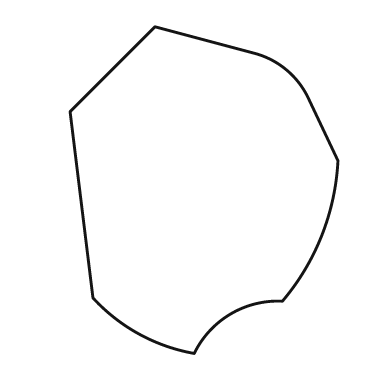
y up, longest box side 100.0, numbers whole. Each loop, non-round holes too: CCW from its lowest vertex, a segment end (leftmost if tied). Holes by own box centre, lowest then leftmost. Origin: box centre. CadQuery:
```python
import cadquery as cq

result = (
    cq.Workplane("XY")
    .moveTo(-3.0, -50.0)
    .threePointArc((8.0, -38.0), (24.0, -34.0))
    .threePointArc((36.0, -14.0), (41.0, 9.0))
    .lineTo(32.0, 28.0)
    .threePointArc((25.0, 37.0), (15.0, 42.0))
    .lineTo(-15.0, 50.0)
    .lineTo(-41.0, 24.0)
    .lineTo(-34.0, -33.0)
    .threePointArc((-20.0, -44.0), (-3.0, -50.0))
    .close()
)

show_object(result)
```